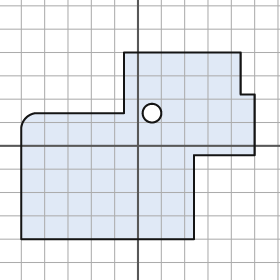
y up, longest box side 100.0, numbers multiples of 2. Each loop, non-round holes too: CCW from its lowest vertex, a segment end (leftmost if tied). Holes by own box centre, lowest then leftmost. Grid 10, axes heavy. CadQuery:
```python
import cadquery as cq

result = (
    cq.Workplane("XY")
    .moveTo(-50.0, -40.0)
    .lineTo(24.0, -40.0)
    .lineTo(24.0, -4.0)
    .lineTo(50.0, -4.0)
    .lineTo(50.0, 22.0)
    .lineTo(44.0, 22.0)
    .lineTo(44.0, 40.0)
    .lineTo(-6.0, 40.0)
    .lineTo(-6.0, 14.0)
    .lineTo(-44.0, 14.0)
    .threePointArc((-48.0, 12.0), (-50.0, 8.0))
    .close()
    .moveTo(6.0, 14.0)
    .circle(4.0)
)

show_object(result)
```